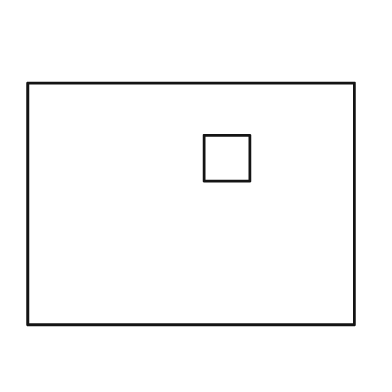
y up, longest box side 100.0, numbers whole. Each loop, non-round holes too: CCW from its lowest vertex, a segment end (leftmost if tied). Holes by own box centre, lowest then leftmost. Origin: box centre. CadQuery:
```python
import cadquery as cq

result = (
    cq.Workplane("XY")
    .moveTo(-50.0, -37.0)
    .lineTo(50.0, -37.0)
    .lineTo(50.0, 37.0)
    .lineTo(-50.0, 37.0)
    .close()
    .moveTo(4.0, 7.0)
    .lineTo(18.0, 7.0)
    .lineTo(18.0, 21.0)
    .lineTo(4.0, 21.0)
    .close()
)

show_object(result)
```